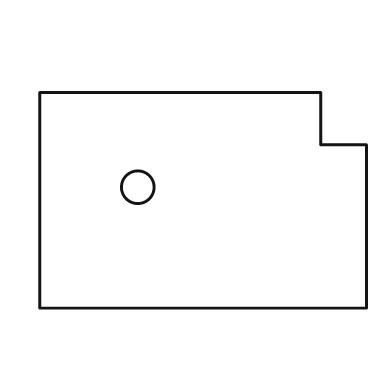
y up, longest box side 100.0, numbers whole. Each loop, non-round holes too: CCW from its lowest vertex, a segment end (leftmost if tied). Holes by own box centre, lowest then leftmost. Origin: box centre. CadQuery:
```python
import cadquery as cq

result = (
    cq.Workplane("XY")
    .moveTo(-50.0, -33.0)
    .lineTo(50.0, -33.0)
    .lineTo(50.0, 17.0)
    .lineTo(36.0, 17.0)
    .lineTo(36.0, 33.0)
    .lineTo(-50.0, 33.0)
    .close()
    .moveTo(-20.0, 4.0)
    .circle(5.0)
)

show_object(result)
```